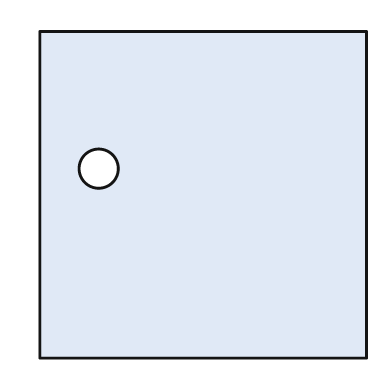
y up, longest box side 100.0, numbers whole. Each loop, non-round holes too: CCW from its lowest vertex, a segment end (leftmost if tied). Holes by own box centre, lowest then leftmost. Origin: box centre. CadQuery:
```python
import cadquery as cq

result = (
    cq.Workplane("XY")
    .moveTo(-50.0, -50.0)
    .lineTo(50.0, -50.0)
    .lineTo(50.0, 50.0)
    .lineTo(-50.0, 50.0)
    .close()
    .moveTo(-32.0, 8.0)
    .circle(6.0)
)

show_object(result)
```